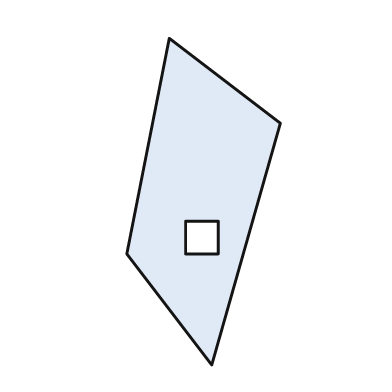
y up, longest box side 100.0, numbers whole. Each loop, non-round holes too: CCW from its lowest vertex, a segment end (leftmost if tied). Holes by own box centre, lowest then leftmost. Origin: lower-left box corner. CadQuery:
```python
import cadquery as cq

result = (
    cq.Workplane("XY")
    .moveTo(26.0, 0.0)
    .lineTo(47.0, 74.0)
    .lineTo(13.0, 100.0)
    .lineTo(0.0, 34.0)
    .close()
    .moveTo(18.0, 34.0)
    .lineTo(28.0, 34.0)
    .lineTo(28.0, 44.0)
    .lineTo(18.0, 44.0)
    .close()
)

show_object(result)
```